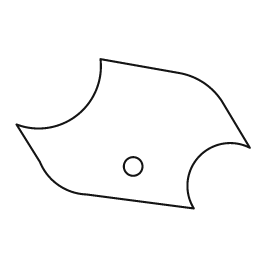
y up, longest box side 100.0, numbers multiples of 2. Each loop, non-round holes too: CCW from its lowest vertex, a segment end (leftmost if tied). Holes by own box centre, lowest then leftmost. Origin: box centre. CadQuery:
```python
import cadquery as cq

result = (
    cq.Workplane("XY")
    .moveTo(26.0, -32.0)
    .threePointArc((28.0, -10.0), (50.0, -6.0))
    .lineTo(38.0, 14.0)
    .threePointArc((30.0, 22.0), (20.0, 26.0))
    .lineTo(-14.0, 32.0)
    .threePointArc((-24.0, 8.0), (-50.0, 4.0))
    .lineTo(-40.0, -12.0)
    .threePointArc((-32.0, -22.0), (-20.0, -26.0))
    .close()
    .moveTo(0.0, -14.0)
    .circle(4.0)
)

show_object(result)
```